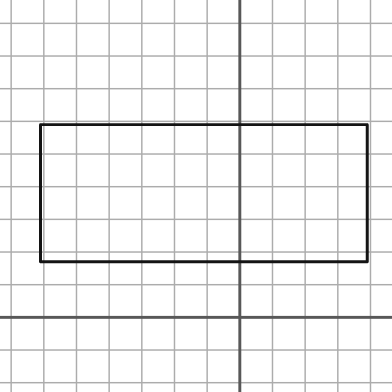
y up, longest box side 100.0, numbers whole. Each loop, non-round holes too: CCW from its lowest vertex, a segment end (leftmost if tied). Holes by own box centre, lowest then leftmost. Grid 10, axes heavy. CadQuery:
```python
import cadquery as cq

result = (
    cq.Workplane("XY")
    .moveTo(-61.0, 17.0)
    .lineTo(39.0, 17.0)
    .lineTo(39.0, 59.0)
    .lineTo(-61.0, 59.0)
    .close()
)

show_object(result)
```